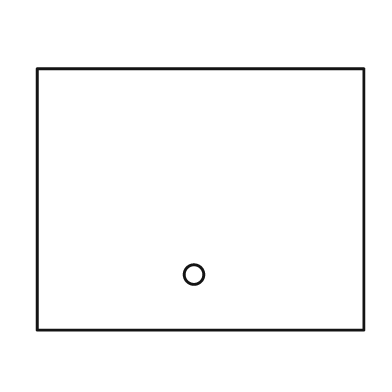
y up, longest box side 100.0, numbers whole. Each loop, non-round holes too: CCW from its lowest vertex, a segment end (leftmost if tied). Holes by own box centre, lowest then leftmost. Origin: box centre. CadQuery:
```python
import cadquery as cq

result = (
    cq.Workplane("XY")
    .moveTo(-50.0, -40.0)
    .lineTo(50.0, -40.0)
    .lineTo(50.0, 40.0)
    .lineTo(-50.0, 40.0)
    .close()
    .moveTo(-2.0, -23.0)
    .circle(3.0)
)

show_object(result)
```